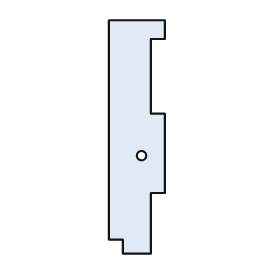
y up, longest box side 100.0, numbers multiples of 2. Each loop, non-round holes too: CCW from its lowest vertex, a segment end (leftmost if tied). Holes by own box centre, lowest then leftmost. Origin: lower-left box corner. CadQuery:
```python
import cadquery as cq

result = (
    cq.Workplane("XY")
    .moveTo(6.0, 0.0)
    .lineTo(18.0, 0.0)
    .lineTo(18.0, 26.0)
    .lineTo(24.0, 26.0)
    .lineTo(24.0, 60.0)
    .lineTo(18.0, 60.0)
    .lineTo(18.0, 92.0)
    .lineTo(24.0, 92.0)
    .lineTo(24.0, 100.0)
    .lineTo(0.0, 100.0)
    .lineTo(0.0, 6.0)
    .lineTo(6.0, 6.0)
    .close()
    .moveTo(14.0, 42.0)
    .circle(2.0)
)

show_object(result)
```